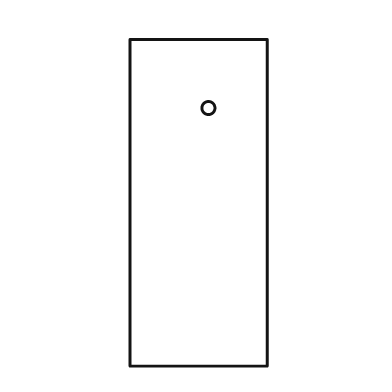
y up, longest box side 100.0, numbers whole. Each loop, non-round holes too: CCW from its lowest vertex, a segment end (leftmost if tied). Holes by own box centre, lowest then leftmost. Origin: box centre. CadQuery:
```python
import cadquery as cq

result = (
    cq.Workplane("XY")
    .moveTo(-21.0, -50.0)
    .lineTo(21.0, -50.0)
    .lineTo(21.0, 50.0)
    .lineTo(-21.0, 50.0)
    .close()
    .moveTo(3.0, 29.0)
    .circle(2.0)
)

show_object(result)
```